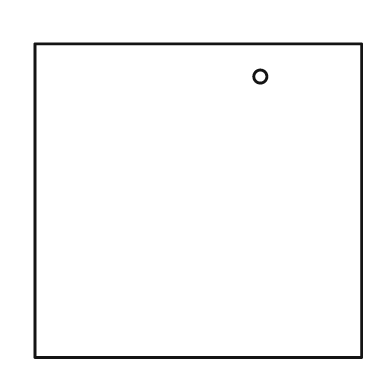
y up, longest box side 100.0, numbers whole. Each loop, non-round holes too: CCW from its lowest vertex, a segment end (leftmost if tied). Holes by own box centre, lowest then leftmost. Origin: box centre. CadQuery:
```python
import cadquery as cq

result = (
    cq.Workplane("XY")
    .moveTo(-50.0, -48.0)
    .lineTo(50.0, -48.0)
    .lineTo(50.0, 48.0)
    .lineTo(-50.0, 48.0)
    .close()
    .moveTo(19.0, 38.0)
    .circle(2.0)
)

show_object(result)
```